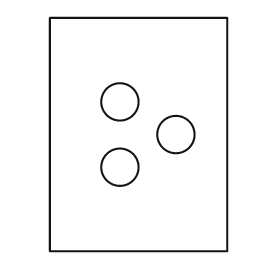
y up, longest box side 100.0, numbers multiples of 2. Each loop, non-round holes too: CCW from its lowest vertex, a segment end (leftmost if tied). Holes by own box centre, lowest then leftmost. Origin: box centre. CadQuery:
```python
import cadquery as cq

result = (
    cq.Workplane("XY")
    .moveTo(-38.0, -50.0)
    .lineTo(38.0, -50.0)
    .lineTo(38.0, 50.0)
    .lineTo(-38.0, 50.0)
    .close()
    .moveTo(-8.0, -14.0)
    .circle(8.0)
    .moveTo(16.0, 0.0)
    .circle(8.0)
    .moveTo(-8.0, 14.0)
    .circle(8.0)
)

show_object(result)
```